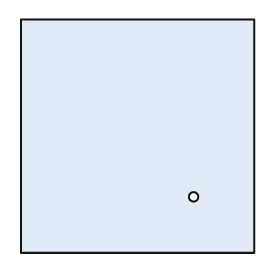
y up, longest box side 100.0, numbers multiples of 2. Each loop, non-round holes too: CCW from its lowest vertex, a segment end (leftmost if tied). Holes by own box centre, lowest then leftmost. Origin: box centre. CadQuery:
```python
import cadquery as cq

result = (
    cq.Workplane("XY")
    .moveTo(-50.0, -50.0)
    .lineTo(50.0, -50.0)
    .lineTo(50.0, 50.0)
    .lineTo(-50.0, 50.0)
    .close()
    .moveTo(24.0, -26.0)
    .circle(2.0)
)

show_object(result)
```